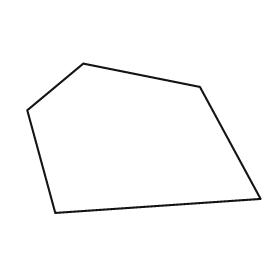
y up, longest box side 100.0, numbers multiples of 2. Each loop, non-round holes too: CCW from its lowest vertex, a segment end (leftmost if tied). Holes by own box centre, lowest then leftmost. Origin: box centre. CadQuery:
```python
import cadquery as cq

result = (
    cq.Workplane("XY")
    .moveTo(-38.0, -32.0)
    .lineTo(50.0, -26.0)
    .lineTo(24.0, 22.0)
    .lineTo(-26.0, 32.0)
    .lineTo(-50.0, 12.0)
    .close()
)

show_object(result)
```